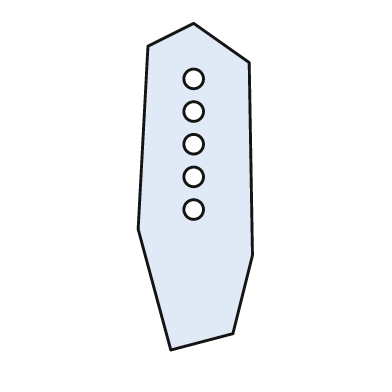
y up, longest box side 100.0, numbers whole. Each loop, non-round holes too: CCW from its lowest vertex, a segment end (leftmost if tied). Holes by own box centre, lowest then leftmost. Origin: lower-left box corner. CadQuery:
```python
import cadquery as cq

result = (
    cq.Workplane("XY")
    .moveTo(10.0, 0.0)
    .lineTo(29.0, 5.0)
    .lineTo(35.0, 29.0)
    .lineTo(34.0, 88.0)
    .lineTo(17.0, 100.0)
    .lineTo(3.0, 93.0)
    .lineTo(0.0, 37.0)
    .close()
    .moveTo(17.0, 43.0)
    .circle(3.0)
    .moveTo(17.0, 53.0)
    .circle(3.0)
    .moveTo(17.0, 63.0)
    .circle(3.0)
    .moveTo(17.0, 73.0)
    .circle(3.0)
    .moveTo(17.0, 83.0)
    .circle(3.0)
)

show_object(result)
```